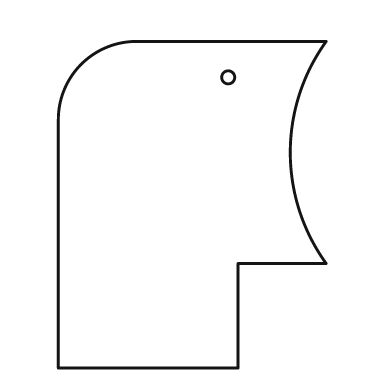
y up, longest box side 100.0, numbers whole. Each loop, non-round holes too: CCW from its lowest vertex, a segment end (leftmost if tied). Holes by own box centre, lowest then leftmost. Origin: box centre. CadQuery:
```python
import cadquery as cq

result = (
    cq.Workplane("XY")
    .moveTo(-41.0, -50.0)
    .lineTo(14.0, -50.0)
    .lineTo(14.0, -18.0)
    .lineTo(41.0, -18.0)
    .threePointArc((30.0, 16.0), (41.0, 50.0))
    .lineTo(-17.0, 50.0)
    .threePointArc((-34.0, 43.0), (-41.0, 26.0))
    .close()
    .moveTo(11.0, 39.0)
    .circle(2.0)
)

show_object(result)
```